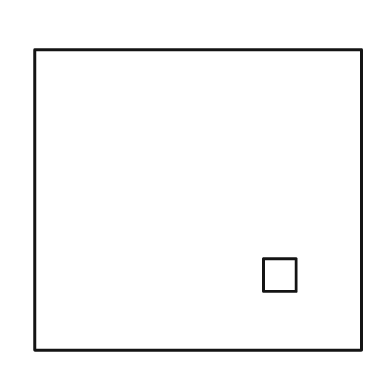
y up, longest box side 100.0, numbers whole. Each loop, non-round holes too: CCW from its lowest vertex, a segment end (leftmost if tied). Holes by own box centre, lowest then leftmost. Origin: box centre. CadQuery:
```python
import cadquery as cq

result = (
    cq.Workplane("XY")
    .moveTo(-50.0, -46.0)
    .lineTo(50.0, -46.0)
    .lineTo(50.0, 46.0)
    .lineTo(-50.0, 46.0)
    .close()
    .moveTo(20.0, -28.0)
    .lineTo(30.0, -28.0)
    .lineTo(30.0, -18.0)
    .lineTo(20.0, -18.0)
    .close()
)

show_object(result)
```